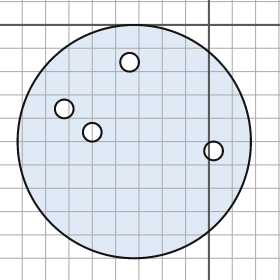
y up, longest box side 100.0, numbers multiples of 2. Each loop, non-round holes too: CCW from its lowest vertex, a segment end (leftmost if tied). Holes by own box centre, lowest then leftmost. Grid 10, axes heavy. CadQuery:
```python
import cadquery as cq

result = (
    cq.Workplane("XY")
    .moveTo(-32.0, -50.0)
    .circle(50.0)
    .moveTo(2.0, -54.0)
    .circle(4.0)
    .moveTo(-50.0, -46.0)
    .circle(4.0)
    .moveTo(-62.0, -36.0)
    .circle(4.0)
    .moveTo(-34.0, -16.0)
    .circle(4.0)
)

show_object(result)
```